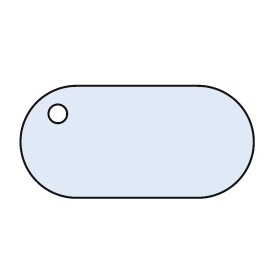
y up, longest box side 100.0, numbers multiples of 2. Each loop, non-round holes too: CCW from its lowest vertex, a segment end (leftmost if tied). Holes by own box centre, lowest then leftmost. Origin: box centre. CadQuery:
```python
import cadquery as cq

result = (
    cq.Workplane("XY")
    .moveTo(-26.0, -24.0)
    .lineTo(26.0, -24.0)
    .threePointArc((50.0, 0.0), (26.0, 24.0))
    .lineTo(-26.0, 24.0)
    .threePointArc((-50.0, 0.0), (-26.0, -24.0))
    .close()
    .moveTo(-34.0, 12.0)
    .circle(4.0)
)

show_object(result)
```